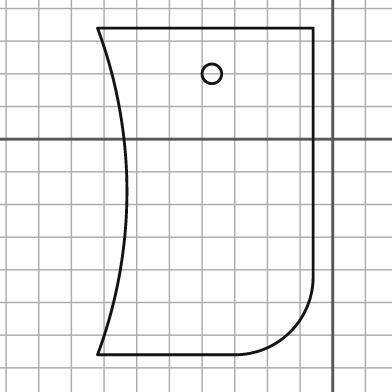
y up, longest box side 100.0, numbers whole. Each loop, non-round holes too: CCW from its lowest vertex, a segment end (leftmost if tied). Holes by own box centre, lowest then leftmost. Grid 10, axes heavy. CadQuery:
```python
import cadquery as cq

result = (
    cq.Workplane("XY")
    .moveTo(-72.0, -66.0)
    .lineTo(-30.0, -66.0)
    .threePointArc((-13.0, -59.0), (-6.0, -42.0))
    .lineTo(-6.0, 34.0)
    .lineTo(-72.0, 34.0)
    .threePointArc((-63.0, -16.0), (-72.0, -66.0))
    .close()
    .moveTo(-37.0, 20.0)
    .circle(3.0)
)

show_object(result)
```